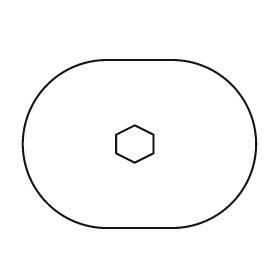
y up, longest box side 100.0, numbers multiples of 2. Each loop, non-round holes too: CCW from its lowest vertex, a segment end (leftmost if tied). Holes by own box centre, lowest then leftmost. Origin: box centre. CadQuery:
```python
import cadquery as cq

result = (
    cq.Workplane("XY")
    .moveTo(-14.0, -36.0)
    .lineTo(14.0, -36.0)
    .threePointArc((50.0, 0.0), (14.0, 36.0))
    .lineTo(-14.0, 36.0)
    .threePointArc((-50.0, 0.0), (-14.0, -36.0))
    .close()
    .moveTo(-2.0, -8.0)
    .lineTo(6.0, -4.0)
    .lineTo(6.0, 4.0)
    .lineTo(-2.0, 8.0)
    .lineTo(-10.0, 4.0)
    .lineTo(-10.0, -4.0)
    .close()
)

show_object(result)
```